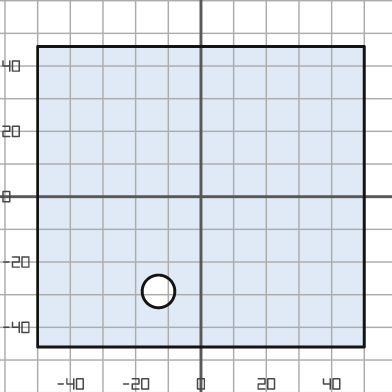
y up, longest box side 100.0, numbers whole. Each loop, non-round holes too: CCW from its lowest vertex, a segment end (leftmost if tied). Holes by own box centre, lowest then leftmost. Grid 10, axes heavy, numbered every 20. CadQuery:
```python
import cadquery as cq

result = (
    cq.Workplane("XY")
    .moveTo(-50.0, -46.0)
    .lineTo(50.0, -46.0)
    .lineTo(50.0, 46.0)
    .lineTo(-50.0, 46.0)
    .close()
    .moveTo(-13.0, -29.0)
    .circle(5.0)
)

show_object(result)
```